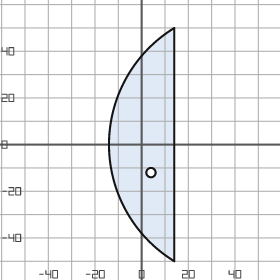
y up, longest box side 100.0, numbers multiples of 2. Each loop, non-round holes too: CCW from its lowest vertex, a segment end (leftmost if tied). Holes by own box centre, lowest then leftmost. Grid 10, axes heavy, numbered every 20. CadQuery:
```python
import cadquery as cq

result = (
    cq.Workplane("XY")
    .moveTo(14.0, -50.0)
    .lineTo(14.0, 50.0)
    .threePointArc((-14.0, 0.0), (14.0, -50.0))
    .close()
    .moveTo(4.0, -12.0)
    .circle(2.0)
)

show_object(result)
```